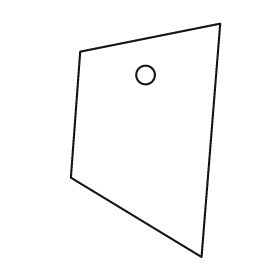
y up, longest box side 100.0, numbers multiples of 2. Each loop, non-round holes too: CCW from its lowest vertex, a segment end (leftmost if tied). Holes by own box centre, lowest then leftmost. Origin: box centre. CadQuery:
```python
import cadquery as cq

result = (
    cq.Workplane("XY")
    .moveTo(24.0, -50.0)
    .lineTo(32.0, 50.0)
    .lineTo(-28.0, 38.0)
    .lineTo(-32.0, -16.0)
    .close()
    .moveTo(0.0, 28.0)
    .circle(4.0)
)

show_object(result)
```